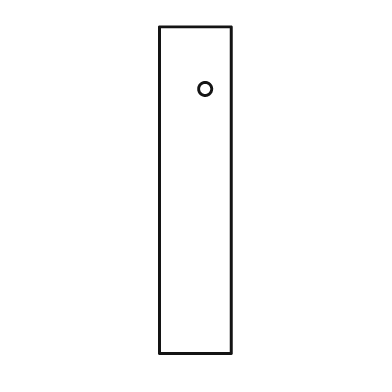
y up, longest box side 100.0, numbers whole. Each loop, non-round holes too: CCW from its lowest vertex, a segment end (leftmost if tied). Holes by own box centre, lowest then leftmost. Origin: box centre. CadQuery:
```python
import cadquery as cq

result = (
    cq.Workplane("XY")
    .moveTo(-11.0, -50.0)
    .lineTo(11.0, -50.0)
    .lineTo(11.0, 50.0)
    .lineTo(-11.0, 50.0)
    .close()
    .moveTo(3.0, 31.0)
    .circle(2.0)
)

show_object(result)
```